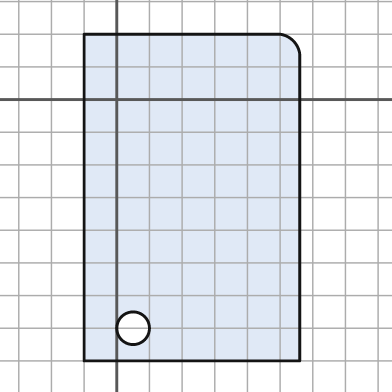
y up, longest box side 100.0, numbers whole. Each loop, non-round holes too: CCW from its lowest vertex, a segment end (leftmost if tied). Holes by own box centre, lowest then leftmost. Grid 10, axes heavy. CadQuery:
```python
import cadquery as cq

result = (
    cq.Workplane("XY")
    .moveTo(-10.0, -80.0)
    .lineTo(56.0, -80.0)
    .lineTo(56.0, 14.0)
    .threePointArc((54.0, 18.0), (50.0, 20.0))
    .lineTo(-10.0, 20.0)
    .close()
    .moveTo(5.0, -70.0)
    .circle(5.0)
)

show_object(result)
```